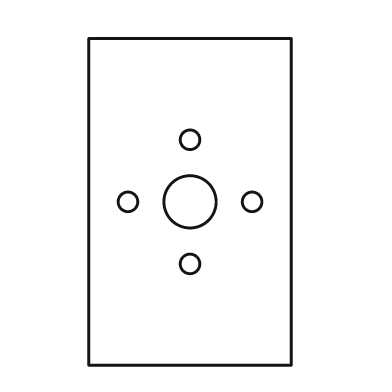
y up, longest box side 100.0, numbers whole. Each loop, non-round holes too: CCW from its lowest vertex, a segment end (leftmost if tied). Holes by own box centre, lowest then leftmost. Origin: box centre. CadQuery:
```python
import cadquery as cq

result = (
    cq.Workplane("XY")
    .moveTo(-31.0, -50.0)
    .lineTo(31.0, -50.0)
    .lineTo(31.0, 50.0)
    .lineTo(-31.0, 50.0)
    .close()
    .moveTo(0.0, -19.0)
    .circle(3.0)
    .moveTo(-19.0, 0.0)
    .circle(3.0)
    .moveTo(0.0, 0.0)
    .circle(8.0)
    .moveTo(19.0, 0.0)
    .circle(3.0)
    .moveTo(0.0, 19.0)
    .circle(3.0)
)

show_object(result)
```